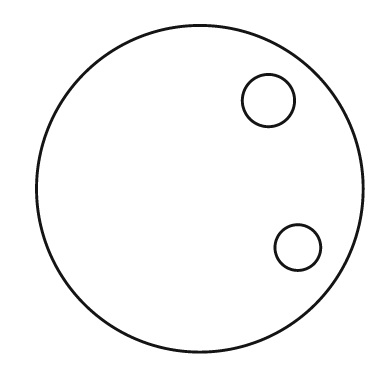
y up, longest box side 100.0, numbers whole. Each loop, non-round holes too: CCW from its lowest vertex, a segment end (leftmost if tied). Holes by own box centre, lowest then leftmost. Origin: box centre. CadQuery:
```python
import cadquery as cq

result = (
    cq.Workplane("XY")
    .moveTo(0.0, 0.0)
    .circle(50.0)
    .moveTo(30.0, -18.0)
    .circle(7.0)
    .moveTo(21.0, 27.0)
    .circle(8.0)
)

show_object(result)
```